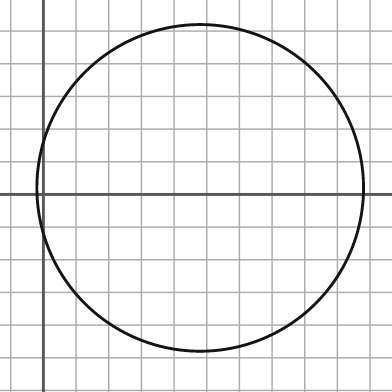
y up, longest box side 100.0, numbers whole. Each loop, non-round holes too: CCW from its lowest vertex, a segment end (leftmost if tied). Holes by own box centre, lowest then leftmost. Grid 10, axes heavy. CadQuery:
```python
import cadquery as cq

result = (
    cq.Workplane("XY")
    .moveTo(48.0, 2.0)
    .circle(50.0)
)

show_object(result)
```